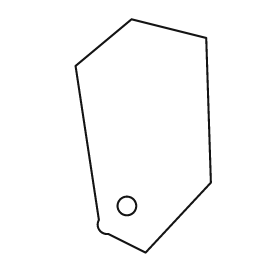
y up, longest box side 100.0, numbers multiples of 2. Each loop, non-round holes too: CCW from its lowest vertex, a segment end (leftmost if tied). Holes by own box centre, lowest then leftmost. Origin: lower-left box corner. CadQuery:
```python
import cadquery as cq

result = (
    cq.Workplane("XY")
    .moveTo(30.0, 0.0)
    .lineTo(58.0, 30.0)
    .lineTo(56.0, 92.0)
    .lineTo(24.0, 100.0)
    .lineTo(0.0, 80.0)
    .lineTo(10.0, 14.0)
    .threePointArc((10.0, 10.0), (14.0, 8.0))
    .close()
    .moveTo(22.0, 20.0)
    .circle(4.0)
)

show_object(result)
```